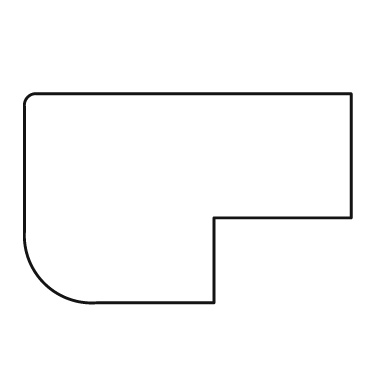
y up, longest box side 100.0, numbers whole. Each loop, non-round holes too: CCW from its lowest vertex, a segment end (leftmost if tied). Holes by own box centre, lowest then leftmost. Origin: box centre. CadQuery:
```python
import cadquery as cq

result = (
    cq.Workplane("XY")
    .moveTo(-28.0, -32.0)
    .lineTo(8.0, -32.0)
    .lineTo(8.0, -6.0)
    .lineTo(50.0, -6.0)
    .lineTo(50.0, 32.0)
    .lineTo(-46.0, 32.0)
    .threePointArc((-49.0, 31.0), (-50.0, 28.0))
    .lineTo(-50.0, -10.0)
    .threePointArc((-44.0, -26.0), (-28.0, -32.0))
    .close()
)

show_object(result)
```